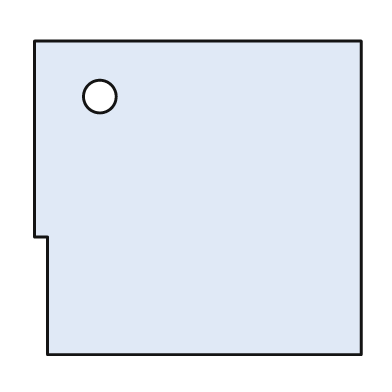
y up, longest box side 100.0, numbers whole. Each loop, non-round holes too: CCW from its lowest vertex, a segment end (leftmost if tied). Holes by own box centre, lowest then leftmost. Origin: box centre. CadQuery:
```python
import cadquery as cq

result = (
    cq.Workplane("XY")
    .moveTo(-46.0, -48.0)
    .lineTo(50.0, -48.0)
    .lineTo(50.0, 48.0)
    .lineTo(-50.0, 48.0)
    .lineTo(-50.0, -12.0)
    .lineTo(-46.0, -12.0)
    .close()
    .moveTo(-30.0, 31.0)
    .circle(5.0)
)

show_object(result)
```